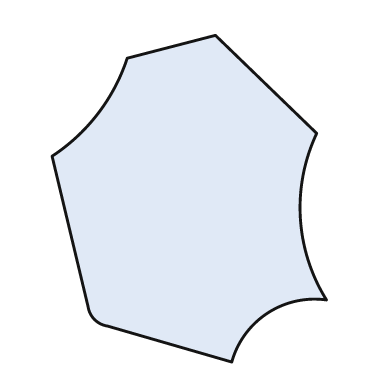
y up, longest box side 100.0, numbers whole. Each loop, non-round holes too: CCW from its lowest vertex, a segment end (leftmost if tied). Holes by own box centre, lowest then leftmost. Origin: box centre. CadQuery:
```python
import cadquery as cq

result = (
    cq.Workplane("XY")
    .moveTo(13.0, -50.0)
    .threePointArc((24.0, -35.0), (42.0, -31.0))
    .threePointArc((34.0, -6.0), (39.0, 20.0))
    .lineTo(8.0, 50.0)
    .lineTo(-19.0, 43.0)
    .threePointArc((-28.0, 26.0), (-42.0, 13.0))
    .lineTo(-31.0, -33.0)
    .threePointArc((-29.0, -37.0), (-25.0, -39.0))
    .close()
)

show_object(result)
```